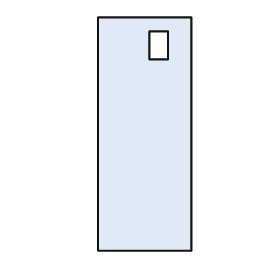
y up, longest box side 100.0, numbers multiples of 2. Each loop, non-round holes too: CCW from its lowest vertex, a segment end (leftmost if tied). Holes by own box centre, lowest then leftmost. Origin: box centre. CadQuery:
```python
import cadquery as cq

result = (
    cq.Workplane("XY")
    .moveTo(-20.0, -50.0)
    .lineTo(20.0, -50.0)
    .lineTo(20.0, 50.0)
    .lineTo(-20.0, 50.0)
    .close()
    .moveTo(2.0, 32.0)
    .lineTo(10.0, 32.0)
    .lineTo(10.0, 44.0)
    .lineTo(2.0, 44.0)
    .close()
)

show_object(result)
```